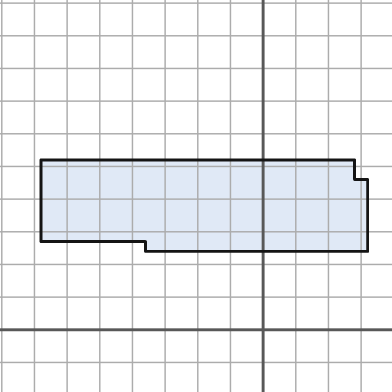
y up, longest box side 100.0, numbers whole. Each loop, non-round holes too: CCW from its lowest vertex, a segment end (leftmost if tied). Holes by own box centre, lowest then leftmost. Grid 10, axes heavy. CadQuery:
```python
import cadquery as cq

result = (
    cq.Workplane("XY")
    .moveTo(-36.0, 24.0)
    .lineTo(32.0, 24.0)
    .lineTo(32.0, 46.0)
    .lineTo(28.0, 46.0)
    .lineTo(28.0, 52.0)
    .lineTo(-68.0, 52.0)
    .lineTo(-68.0, 27.0)
    .lineTo(-36.0, 27.0)
    .close()
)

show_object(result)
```